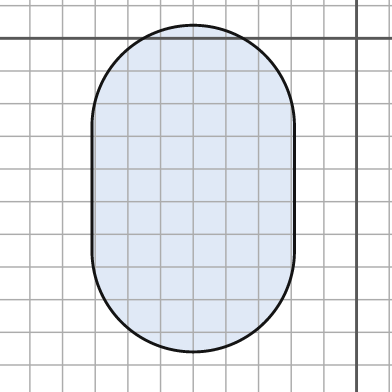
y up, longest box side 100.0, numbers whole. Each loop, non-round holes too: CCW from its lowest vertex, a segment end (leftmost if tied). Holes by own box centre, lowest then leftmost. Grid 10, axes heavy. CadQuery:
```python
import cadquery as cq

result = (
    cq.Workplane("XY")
    .moveTo(-81.0, -65.0)
    .threePointArc((-50.0, -96.0), (-19.0, -65.0))
    .lineTo(-19.0, -27.0)
    .threePointArc((-50.0, 4.0), (-81.0, -27.0))
    .close()
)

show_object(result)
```